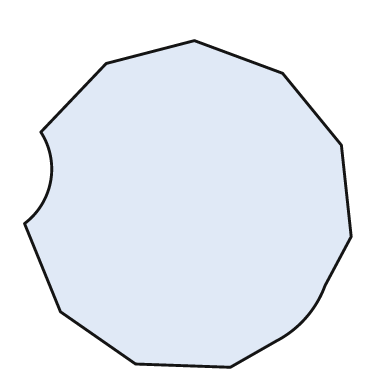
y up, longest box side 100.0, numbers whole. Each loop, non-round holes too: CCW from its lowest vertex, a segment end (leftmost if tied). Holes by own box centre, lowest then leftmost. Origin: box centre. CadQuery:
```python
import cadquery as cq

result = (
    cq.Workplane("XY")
    .moveTo(13.0, -50.0)
    .lineTo(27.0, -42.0)
    .threePointArc((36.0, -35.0), (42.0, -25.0))
    .lineTo(50.0, -10.0)
    .lineTo(47.0, 18.0)
    .lineTo(29.0, 40.0)
    .lineTo(2.0, 50.0)
    .lineTo(-25.0, 43.0)
    .lineTo(-45.0, 22.0)
    .threePointArc((-42.0, 7.0), (-50.0, -6.0))
    .lineTo(-39.0, -33.0)
    .lineTo(-16.0, -49.0)
    .close()
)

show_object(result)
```